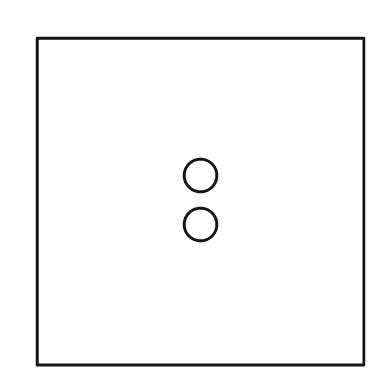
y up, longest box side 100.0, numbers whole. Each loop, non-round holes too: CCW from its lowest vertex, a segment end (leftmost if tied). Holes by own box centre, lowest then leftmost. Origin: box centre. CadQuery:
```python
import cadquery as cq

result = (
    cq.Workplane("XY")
    .moveTo(-50.0, -50.0)
    .lineTo(50.0, -50.0)
    .lineTo(50.0, 50.0)
    .lineTo(-50.0, 50.0)
    .close()
    .moveTo(0.0, -7.0)
    .circle(5.0)
    .moveTo(0.0, 8.0)
    .circle(5.0)
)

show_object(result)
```